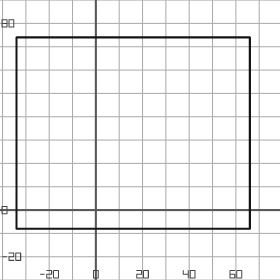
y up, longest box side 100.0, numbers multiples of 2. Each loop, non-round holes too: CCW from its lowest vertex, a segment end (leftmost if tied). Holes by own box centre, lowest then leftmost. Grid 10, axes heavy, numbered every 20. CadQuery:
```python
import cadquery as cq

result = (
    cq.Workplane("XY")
    .moveTo(-34.0, -8.0)
    .lineTo(66.0, -8.0)
    .lineTo(66.0, 74.0)
    .lineTo(-34.0, 74.0)
    .close()
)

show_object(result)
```